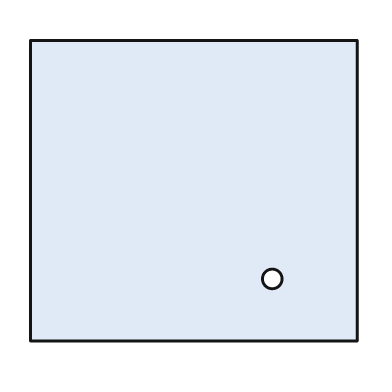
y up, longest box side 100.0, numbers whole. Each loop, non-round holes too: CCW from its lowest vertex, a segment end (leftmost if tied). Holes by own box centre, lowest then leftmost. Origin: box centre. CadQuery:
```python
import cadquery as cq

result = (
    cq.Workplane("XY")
    .moveTo(-50.0, -46.0)
    .lineTo(50.0, -46.0)
    .lineTo(50.0, 46.0)
    .lineTo(-50.0, 46.0)
    .close()
    .moveTo(24.0, -27.0)
    .circle(3.0)
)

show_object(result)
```